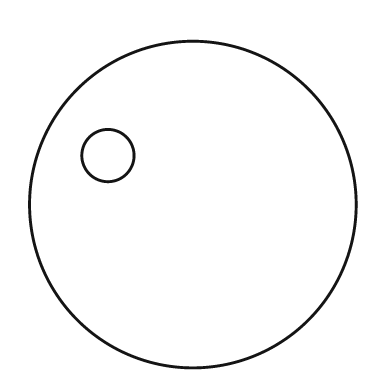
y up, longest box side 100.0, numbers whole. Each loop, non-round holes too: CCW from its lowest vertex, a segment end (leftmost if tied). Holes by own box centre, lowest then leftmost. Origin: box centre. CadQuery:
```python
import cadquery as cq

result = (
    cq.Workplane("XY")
    .moveTo(0.0, 0.0)
    .circle(50.0)
    .moveTo(-26.0, 15.0)
    .circle(8.0)
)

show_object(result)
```